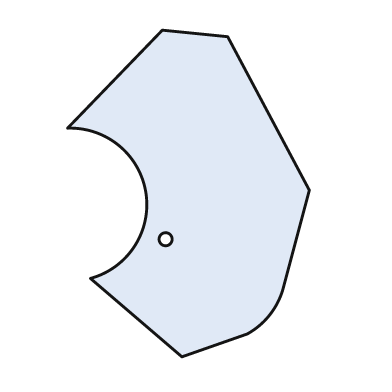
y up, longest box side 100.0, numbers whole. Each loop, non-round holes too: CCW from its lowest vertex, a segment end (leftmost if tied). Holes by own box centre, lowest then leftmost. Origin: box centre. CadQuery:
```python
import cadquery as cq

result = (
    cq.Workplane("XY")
    .moveTo(-2.0, -50.0)
    .lineTo(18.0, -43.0)
    .threePointArc((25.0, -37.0), (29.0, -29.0))
    .lineTo(37.0, 1.0)
    .lineTo(12.0, 48.0)
    .lineTo(-8.0, 50.0)
    .lineTo(-37.0, 20.0)
    .threePointArc((-13.0, 0.0), (-30.0, -26.0))
    .close()
    .moveTo(-7.0, -14.0)
    .circle(2.0)
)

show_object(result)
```